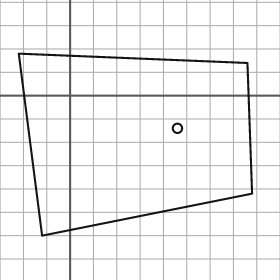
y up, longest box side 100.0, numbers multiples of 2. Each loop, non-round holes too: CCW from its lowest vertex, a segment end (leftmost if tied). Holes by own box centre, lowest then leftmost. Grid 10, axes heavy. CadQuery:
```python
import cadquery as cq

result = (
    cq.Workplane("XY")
    .moveTo(-12.0, -60.0)
    .lineTo(78.0, -42.0)
    .lineTo(76.0, 14.0)
    .lineTo(-22.0, 18.0)
    .close()
    .moveTo(46.0, -14.0)
    .circle(2.0)
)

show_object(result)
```